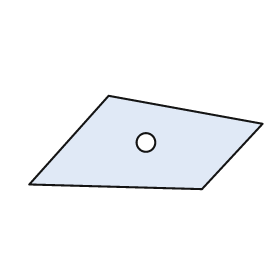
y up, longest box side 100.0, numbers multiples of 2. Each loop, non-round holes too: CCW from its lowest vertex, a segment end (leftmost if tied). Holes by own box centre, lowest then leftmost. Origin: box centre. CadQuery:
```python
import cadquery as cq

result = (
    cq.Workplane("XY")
    .moveTo(24.0, -20.0)
    .lineTo(50.0, 8.0)
    .lineTo(-16.0, 20.0)
    .lineTo(-50.0, -18.0)
    .close()
    .moveTo(0.0, 0.0)
    .circle(4.0)
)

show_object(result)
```